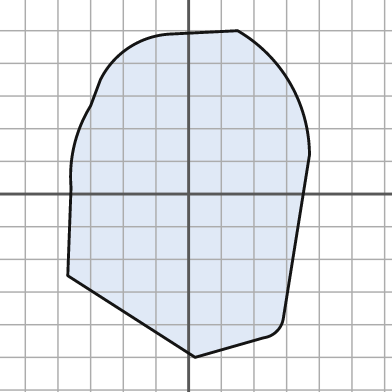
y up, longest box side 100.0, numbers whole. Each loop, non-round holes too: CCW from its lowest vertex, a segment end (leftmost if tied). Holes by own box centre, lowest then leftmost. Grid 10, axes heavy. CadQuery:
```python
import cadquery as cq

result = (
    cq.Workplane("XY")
    .moveTo(2.0, -50.0)
    .lineTo(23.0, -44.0)
    .threePointArc((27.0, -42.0), (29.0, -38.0))
    .lineTo(37.0, 12.0)
    .threePointArc((31.0, 34.0), (15.0, 50.0))
    .lineTo(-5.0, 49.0)
    .threePointArc((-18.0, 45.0), (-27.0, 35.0))
    .lineTo(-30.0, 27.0)
    .threePointArc((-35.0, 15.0), (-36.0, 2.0))
    .lineTo(-37.0, -25.0)
    .close()
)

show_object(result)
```